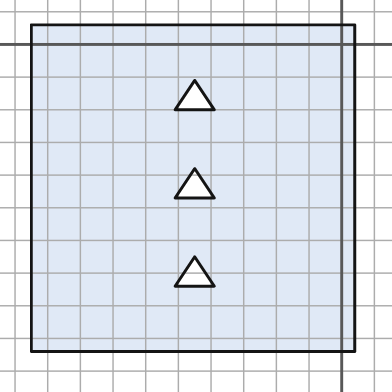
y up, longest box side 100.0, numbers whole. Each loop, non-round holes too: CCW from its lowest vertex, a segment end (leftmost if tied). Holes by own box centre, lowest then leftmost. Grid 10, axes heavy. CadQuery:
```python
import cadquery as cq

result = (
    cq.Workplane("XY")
    .moveTo(-95.0, -94.0)
    .lineTo(4.0, -94.0)
    .lineTo(4.0, 6.0)
    .lineTo(-95.0, 6.0)
    .close()
    .moveTo(-51.0, -74.0)
    .lineTo(-39.0, -74.0)
    .lineTo(-45.0, -65.0)
    .close()
    .moveTo(-51.0, -47.0)
    .lineTo(-39.0, -47.0)
    .lineTo(-45.0, -38.0)
    .close()
    .moveTo(-51.0, -20.0)
    .lineTo(-39.0, -20.0)
    .lineTo(-45.0, -11.0)
    .close()
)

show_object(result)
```